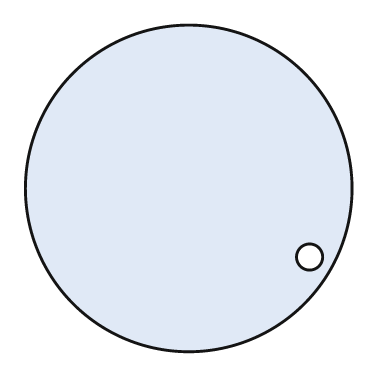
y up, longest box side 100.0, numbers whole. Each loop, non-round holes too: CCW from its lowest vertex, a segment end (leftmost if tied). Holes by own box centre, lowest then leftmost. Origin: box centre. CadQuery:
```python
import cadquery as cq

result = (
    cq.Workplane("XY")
    .moveTo(0.0, 0.0)
    .circle(50.0)
    .moveTo(37.0, -21.0)
    .circle(4.0)
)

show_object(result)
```